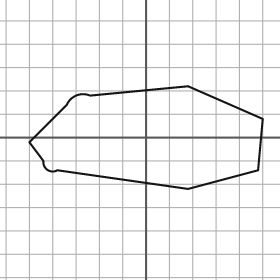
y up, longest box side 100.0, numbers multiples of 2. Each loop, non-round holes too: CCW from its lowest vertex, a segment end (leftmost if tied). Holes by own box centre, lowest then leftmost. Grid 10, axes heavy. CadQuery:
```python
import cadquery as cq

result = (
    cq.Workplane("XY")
    .moveTo(18.0, -22.0)
    .lineTo(48.0, -14.0)
    .lineTo(50.0, 8.0)
    .lineTo(18.0, 22.0)
    .lineTo(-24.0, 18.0)
    .threePointArc((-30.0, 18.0), (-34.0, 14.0))
    .lineTo(-50.0, -2.0)
    .lineTo(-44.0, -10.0)
    .threePointArc((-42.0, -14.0), (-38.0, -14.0))
    .close()
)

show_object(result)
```